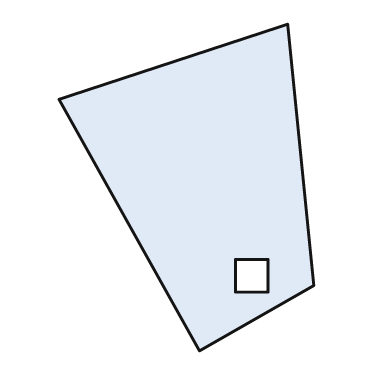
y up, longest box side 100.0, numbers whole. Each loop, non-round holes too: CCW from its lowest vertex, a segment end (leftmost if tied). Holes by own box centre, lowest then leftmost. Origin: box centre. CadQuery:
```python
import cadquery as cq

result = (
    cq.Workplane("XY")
    .moveTo(4.0, -50.0)
    .lineTo(39.0, -30.0)
    .lineTo(31.0, 50.0)
    .lineTo(-39.0, 27.0)
    .close()
    .moveTo(15.0, -32.0)
    .lineTo(25.0, -32.0)
    .lineTo(25.0, -22.0)
    .lineTo(15.0, -22.0)
    .close()
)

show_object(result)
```